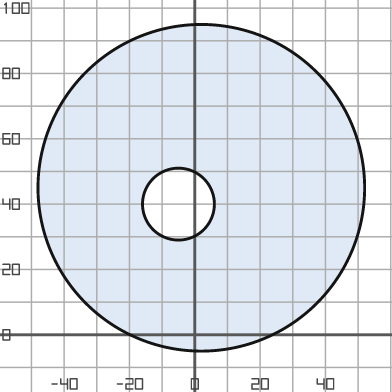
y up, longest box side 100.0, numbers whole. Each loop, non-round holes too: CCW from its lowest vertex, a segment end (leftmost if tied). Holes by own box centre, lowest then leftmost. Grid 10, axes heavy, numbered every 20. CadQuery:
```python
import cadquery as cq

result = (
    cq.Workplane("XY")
    .moveTo(2.0, 45.0)
    .circle(50.0)
    .moveTo(-5.0, 40.0)
    .circle(11.0)
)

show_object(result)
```